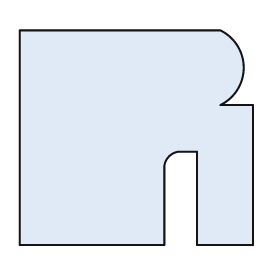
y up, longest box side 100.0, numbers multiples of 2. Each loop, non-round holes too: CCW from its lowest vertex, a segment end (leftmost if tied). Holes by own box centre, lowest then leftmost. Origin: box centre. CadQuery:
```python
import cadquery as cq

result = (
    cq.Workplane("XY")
    .moveTo(-50.0, -46.0)
    .lineTo(12.0, -46.0)
    .lineTo(12.0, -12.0)
    .threePointArc((14.0, -8.0), (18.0, -6.0))
    .lineTo(26.0, -6.0)
    .lineTo(26.0, -46.0)
    .lineTo(50.0, -46.0)
    .lineTo(50.0, 14.0)
    .lineTo(36.0, 14.0)
    .threePointArc((46.0, 30.0), (36.0, 46.0))
    .lineTo(-50.0, 46.0)
    .close()
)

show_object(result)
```